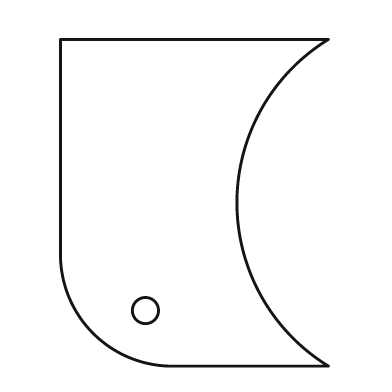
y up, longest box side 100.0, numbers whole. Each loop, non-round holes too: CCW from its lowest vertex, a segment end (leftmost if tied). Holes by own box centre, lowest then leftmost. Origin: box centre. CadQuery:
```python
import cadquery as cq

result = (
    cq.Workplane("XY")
    .moveTo(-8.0, -50.0)
    .lineTo(41.0, -50.0)
    .threePointArc((13.0, 0.0), (41.0, 50.0))
    .lineTo(-41.0, 50.0)
    .lineTo(-41.0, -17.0)
    .threePointArc((-31.0, -40.0), (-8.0, -50.0))
    .close()
    .moveTo(-15.0, -33.0)
    .circle(4.0)
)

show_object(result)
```